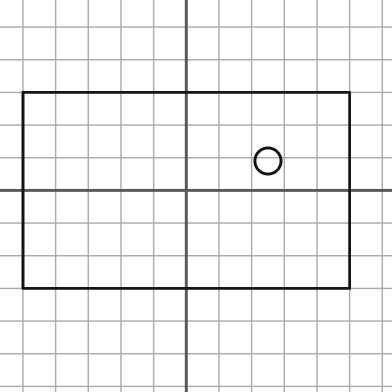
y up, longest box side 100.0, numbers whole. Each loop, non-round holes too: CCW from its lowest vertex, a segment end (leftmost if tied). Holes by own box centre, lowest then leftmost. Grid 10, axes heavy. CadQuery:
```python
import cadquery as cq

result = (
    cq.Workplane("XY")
    .moveTo(-50.0, -30.0)
    .lineTo(50.0, -30.0)
    .lineTo(50.0, 30.0)
    .lineTo(-50.0, 30.0)
    .close()
    .moveTo(25.0, 9.0)
    .circle(4.0)
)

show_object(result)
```